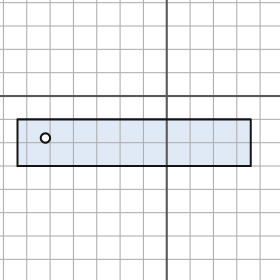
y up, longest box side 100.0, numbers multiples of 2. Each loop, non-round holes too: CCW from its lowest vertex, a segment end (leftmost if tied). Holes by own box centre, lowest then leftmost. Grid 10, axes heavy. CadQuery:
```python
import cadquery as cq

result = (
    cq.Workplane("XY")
    .moveTo(-64.0, -30.0)
    .lineTo(36.0, -30.0)
    .lineTo(36.0, -10.0)
    .lineTo(-64.0, -10.0)
    .close()
    .moveTo(-52.0, -18.0)
    .circle(2.0)
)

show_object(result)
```